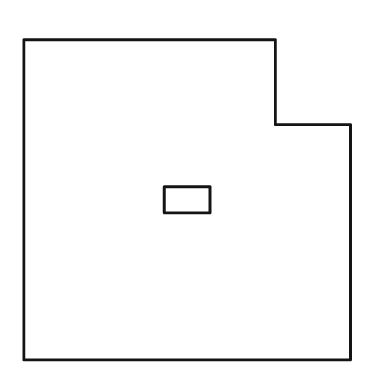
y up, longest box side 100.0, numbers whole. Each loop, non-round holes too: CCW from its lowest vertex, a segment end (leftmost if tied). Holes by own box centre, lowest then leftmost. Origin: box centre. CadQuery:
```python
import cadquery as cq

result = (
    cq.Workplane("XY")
    .moveTo(-50.0, -49.0)
    .lineTo(50.0, -49.0)
    .lineTo(50.0, 23.0)
    .lineTo(27.0, 23.0)
    .lineTo(27.0, 49.0)
    .lineTo(-50.0, 49.0)
    .close()
    .moveTo(-7.0, -4.0)
    .lineTo(7.0, -4.0)
    .lineTo(7.0, 4.0)
    .lineTo(-7.0, 4.0)
    .close()
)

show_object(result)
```